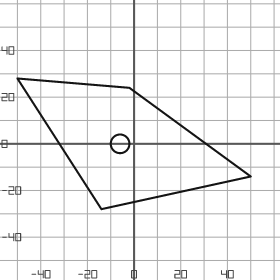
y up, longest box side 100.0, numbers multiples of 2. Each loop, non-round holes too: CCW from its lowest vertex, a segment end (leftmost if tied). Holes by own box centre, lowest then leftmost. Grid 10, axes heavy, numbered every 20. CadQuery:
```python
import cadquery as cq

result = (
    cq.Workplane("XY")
    .moveTo(-14.0, -28.0)
    .lineTo(50.0, -14.0)
    .lineTo(-2.0, 24.0)
    .lineTo(-50.0, 28.0)
    .close()
    .moveTo(-6.0, 0.0)
    .circle(4.0)
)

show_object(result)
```